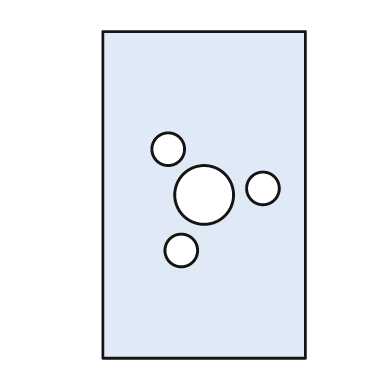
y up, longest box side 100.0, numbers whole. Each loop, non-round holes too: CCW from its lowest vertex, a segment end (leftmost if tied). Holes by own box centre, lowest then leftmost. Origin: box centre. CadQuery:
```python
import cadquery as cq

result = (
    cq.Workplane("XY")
    .moveTo(-31.0, -50.0)
    .lineTo(31.0, -50.0)
    .lineTo(31.0, 50.0)
    .lineTo(-31.0, 50.0)
    .close()
    .moveTo(-7.0, -17.0)
    .circle(5.0)
    .moveTo(0.0, 0.0)
    .circle(9.0)
    .moveTo(18.0, 2.0)
    .circle(5.0)
    .moveTo(-11.0, 14.0)
    .circle(5.0)
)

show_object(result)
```